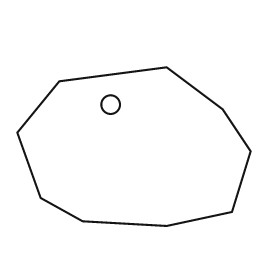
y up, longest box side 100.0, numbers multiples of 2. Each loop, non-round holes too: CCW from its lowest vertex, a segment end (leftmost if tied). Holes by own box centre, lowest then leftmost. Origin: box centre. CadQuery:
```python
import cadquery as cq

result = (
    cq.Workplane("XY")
    .moveTo(14.0, -34.0)
    .lineTo(42.0, -28.0)
    .lineTo(50.0, -2.0)
    .lineTo(38.0, 16.0)
    .lineTo(14.0, 34.0)
    .lineTo(-32.0, 28.0)
    .lineTo(-50.0, 6.0)
    .lineTo(-40.0, -22.0)
    .lineTo(-22.0, -32.0)
    .close()
    .moveTo(-10.0, 18.0)
    .circle(4.0)
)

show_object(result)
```